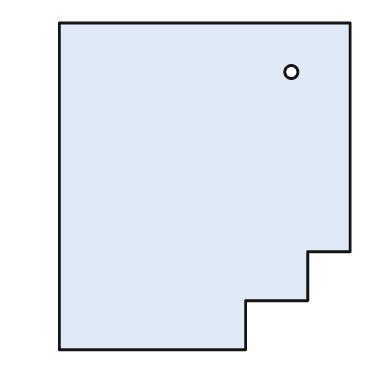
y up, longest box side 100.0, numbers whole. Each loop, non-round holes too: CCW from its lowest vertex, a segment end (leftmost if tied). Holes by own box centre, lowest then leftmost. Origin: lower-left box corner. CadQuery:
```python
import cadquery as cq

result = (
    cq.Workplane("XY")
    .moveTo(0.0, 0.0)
    .lineTo(57.0, 0.0)
    .lineTo(57.0, 15.0)
    .lineTo(76.0, 15.0)
    .lineTo(76.0, 30.0)
    .lineTo(89.0, 30.0)
    .lineTo(89.0, 100.0)
    .lineTo(0.0, 100.0)
    .close()
    .moveTo(71.0, 85.0)
    .circle(2.0)
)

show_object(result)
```